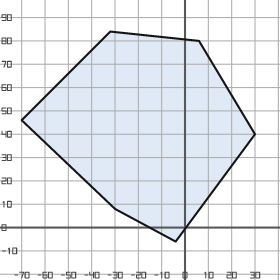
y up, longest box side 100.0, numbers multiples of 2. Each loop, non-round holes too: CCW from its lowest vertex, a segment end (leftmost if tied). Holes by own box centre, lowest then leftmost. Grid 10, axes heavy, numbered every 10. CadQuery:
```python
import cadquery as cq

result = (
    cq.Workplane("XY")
    .moveTo(-4.0, -6.0)
    .lineTo(30.0, 40.0)
    .lineTo(6.0, 80.0)
    .lineTo(-32.0, 84.0)
    .lineTo(-70.0, 46.0)
    .lineTo(-30.0, 8.0)
    .close()
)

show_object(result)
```